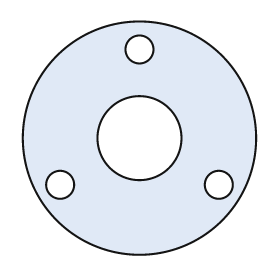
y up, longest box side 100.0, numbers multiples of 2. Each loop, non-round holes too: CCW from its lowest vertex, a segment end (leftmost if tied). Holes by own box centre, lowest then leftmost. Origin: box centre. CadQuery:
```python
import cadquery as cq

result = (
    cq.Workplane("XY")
    .moveTo(0.0, 0.0)
    .circle(50.0)
    .moveTo(-34.0, -20.0)
    .circle(6.0)
    .moveTo(34.0, -20.0)
    .circle(6.0)
    .moveTo(0.0, 0.0)
    .circle(18.0)
    .moveTo(0.0, 38.0)
    .circle(6.0)
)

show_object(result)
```